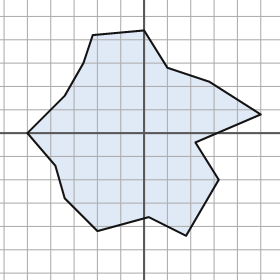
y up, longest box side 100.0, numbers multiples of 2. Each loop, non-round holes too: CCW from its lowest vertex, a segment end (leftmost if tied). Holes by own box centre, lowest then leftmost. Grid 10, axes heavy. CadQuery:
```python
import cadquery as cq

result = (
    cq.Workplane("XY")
    .moveTo(18.0, -44.0)
    .lineTo(32.0, -20.0)
    .lineTo(22.0, -4.0)
    .lineTo(50.0, 8.0)
    .lineTo(28.0, 22.0)
    .lineTo(10.0, 28.0)
    .lineTo(0.0, 44.0)
    .lineTo(-22.0, 42.0)
    .lineTo(-26.0, 30.0)
    .lineTo(-34.0, 16.0)
    .lineTo(-50.0, 0.0)
    .lineTo(-38.0, -14.0)
    .lineTo(-34.0, -28.0)
    .lineTo(-20.0, -42.0)
    .lineTo(2.0, -36.0)
    .close()
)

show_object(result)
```